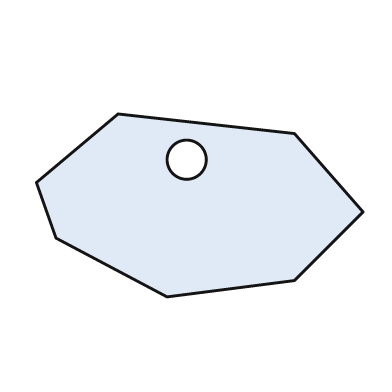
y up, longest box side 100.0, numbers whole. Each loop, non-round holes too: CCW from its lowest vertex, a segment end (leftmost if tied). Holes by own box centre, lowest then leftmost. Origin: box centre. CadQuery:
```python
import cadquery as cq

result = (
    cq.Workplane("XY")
    .moveTo(-10.0, -28.0)
    .lineTo(29.0, -23.0)
    .lineTo(50.0, -2.0)
    .lineTo(29.0, 22.0)
    .lineTo(-25.0, 28.0)
    .lineTo(-50.0, 7.0)
    .lineTo(-44.0, -10.0)
    .close()
    .moveTo(-4.0, 14.0)
    .circle(6.0)
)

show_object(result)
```